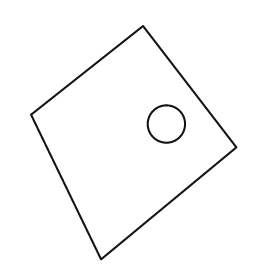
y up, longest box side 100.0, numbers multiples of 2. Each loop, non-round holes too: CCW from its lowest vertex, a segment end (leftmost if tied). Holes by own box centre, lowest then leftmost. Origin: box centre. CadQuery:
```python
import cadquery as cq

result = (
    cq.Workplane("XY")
    .moveTo(-14.0, -50.0)
    .lineTo(44.0, -2.0)
    .lineTo(4.0, 50.0)
    .lineTo(-44.0, 12.0)
    .close()
    .moveTo(14.0, 8.0)
    .circle(8.0)
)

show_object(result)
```